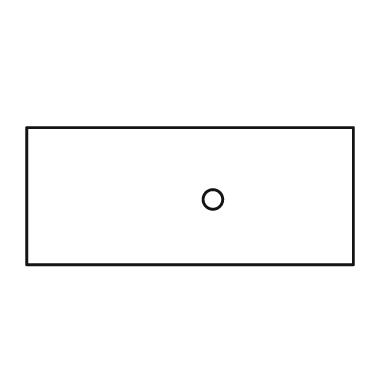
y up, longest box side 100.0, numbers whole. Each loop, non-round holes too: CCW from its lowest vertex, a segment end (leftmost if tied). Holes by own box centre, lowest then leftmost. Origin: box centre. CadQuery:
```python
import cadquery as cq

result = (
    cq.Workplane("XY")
    .moveTo(-50.0, -21.0)
    .lineTo(50.0, -21.0)
    .lineTo(50.0, 21.0)
    .lineTo(-50.0, 21.0)
    .close()
    .moveTo(7.0, -1.0)
    .circle(3.0)
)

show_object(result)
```